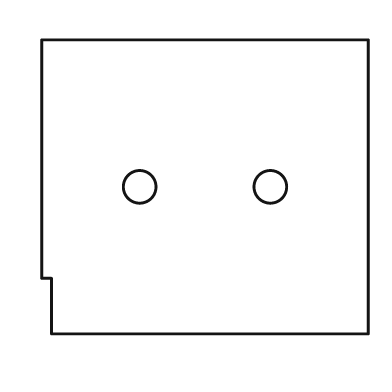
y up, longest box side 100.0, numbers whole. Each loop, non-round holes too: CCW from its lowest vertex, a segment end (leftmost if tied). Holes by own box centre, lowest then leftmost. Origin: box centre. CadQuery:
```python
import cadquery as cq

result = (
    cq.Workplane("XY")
    .moveTo(-47.0, -45.0)
    .lineTo(50.0, -45.0)
    .lineTo(50.0, 45.0)
    .lineTo(-50.0, 45.0)
    .lineTo(-50.0, -28.0)
    .lineTo(-47.0, -28.0)
    .close()
    .moveTo(-20.0, 0.0)
    .circle(5.0)
    .moveTo(20.0, 0.0)
    .circle(5.0)
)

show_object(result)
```